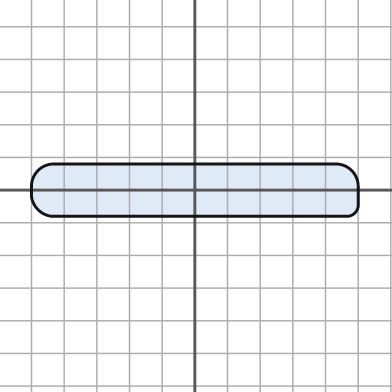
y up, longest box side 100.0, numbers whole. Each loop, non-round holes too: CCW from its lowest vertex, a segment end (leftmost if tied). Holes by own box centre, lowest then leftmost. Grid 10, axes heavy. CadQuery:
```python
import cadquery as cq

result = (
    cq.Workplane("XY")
    .moveTo(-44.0, -8.0)
    .lineTo(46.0, -8.0)
    .threePointArc((49.0, -7.0), (50.0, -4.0))
    .lineTo(50.0, 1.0)
    .threePointArc((48.0, 6.0), (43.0, 8.0))
    .lineTo(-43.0, 8.0)
    .threePointArc((-48.0, 6.0), (-50.0, 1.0))
    .lineTo(-50.0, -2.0)
    .threePointArc((-48.0, -6.0), (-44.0, -8.0))
    .close()
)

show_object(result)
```